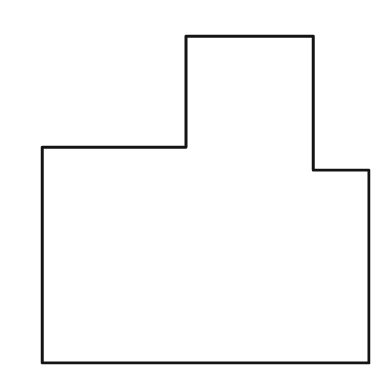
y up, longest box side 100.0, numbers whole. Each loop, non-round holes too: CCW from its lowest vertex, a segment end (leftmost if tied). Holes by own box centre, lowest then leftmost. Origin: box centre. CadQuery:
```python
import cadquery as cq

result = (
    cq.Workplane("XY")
    .moveTo(-50.0, -50.0)
    .lineTo(50.0, -50.0)
    .lineTo(50.0, 9.0)
    .lineTo(33.0, 9.0)
    .lineTo(33.0, 50.0)
    .lineTo(-6.0, 50.0)
    .lineTo(-6.0, 16.0)
    .lineTo(-50.0, 16.0)
    .close()
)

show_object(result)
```